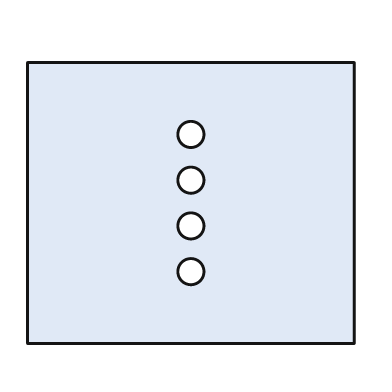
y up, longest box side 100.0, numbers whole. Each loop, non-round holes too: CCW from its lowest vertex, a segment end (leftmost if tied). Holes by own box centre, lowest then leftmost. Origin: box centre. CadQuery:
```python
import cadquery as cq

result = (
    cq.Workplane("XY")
    .moveTo(-50.0, -43.0)
    .lineTo(50.0, -43.0)
    .lineTo(50.0, 43.0)
    .lineTo(-50.0, 43.0)
    .close()
    .moveTo(0.0, -21.0)
    .circle(4.0)
    .moveTo(0.0, -7.0)
    .circle(4.0)
    .moveTo(0.0, 7.0)
    .circle(4.0)
    .moveTo(0.0, 21.0)
    .circle(4.0)
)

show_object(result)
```